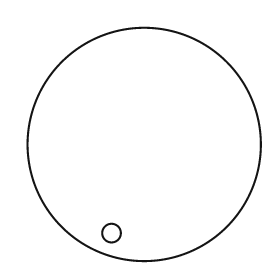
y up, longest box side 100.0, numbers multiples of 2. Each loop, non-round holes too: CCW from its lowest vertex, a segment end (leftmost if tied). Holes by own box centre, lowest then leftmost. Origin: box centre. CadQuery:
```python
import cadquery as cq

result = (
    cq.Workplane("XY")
    .moveTo(0.0, 0.0)
    .circle(50.0)
    .moveTo(-14.0, -38.0)
    .circle(4.0)
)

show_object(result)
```